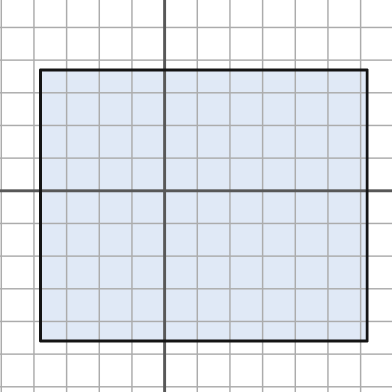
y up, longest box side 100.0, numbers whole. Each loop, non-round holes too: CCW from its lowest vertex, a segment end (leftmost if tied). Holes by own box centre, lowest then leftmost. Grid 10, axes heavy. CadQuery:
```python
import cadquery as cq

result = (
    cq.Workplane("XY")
    .moveTo(-38.0, -46.0)
    .lineTo(62.0, -46.0)
    .lineTo(62.0, 37.0)
    .lineTo(-38.0, 37.0)
    .close()
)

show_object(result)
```